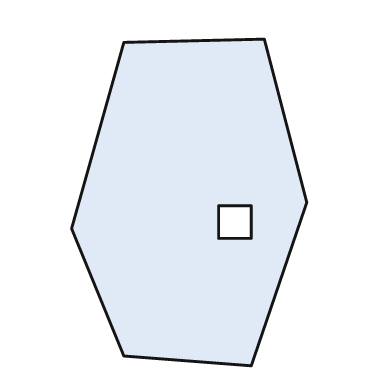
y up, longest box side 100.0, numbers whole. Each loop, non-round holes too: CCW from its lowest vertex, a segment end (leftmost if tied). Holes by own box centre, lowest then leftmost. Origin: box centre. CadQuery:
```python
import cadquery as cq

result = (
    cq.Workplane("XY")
    .moveTo(19.0, -50.0)
    .lineTo(36.0, 0.0)
    .lineTo(23.0, 50.0)
    .lineTo(-20.0, 49.0)
    .lineTo(-36.0, -8.0)
    .lineTo(-20.0, -47.0)
    .close()
    .moveTo(9.0, -11.0)
    .lineTo(19.0, -11.0)
    .lineTo(19.0, -1.0)
    .lineTo(9.0, -1.0)
    .close()
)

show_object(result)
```